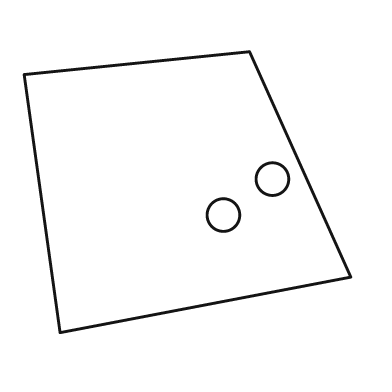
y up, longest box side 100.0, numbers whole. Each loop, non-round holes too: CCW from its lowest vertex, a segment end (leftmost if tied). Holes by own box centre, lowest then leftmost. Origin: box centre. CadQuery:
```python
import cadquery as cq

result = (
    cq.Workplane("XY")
    .moveTo(-39.0, -43.0)
    .lineTo(50.0, -26.0)
    .lineTo(19.0, 43.0)
    .lineTo(-50.0, 36.0)
    .close()
    .moveTo(11.0, -7.0)
    .circle(5.0)
    .moveTo(26.0, 4.0)
    .circle(5.0)
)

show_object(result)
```